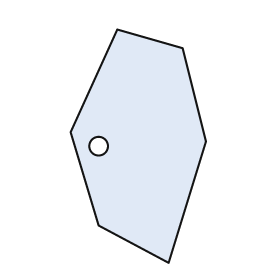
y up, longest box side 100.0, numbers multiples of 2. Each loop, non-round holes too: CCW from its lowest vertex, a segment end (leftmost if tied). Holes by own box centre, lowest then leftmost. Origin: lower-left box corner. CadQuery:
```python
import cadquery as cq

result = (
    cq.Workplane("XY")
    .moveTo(42.0, 0.0)
    .lineTo(58.0, 52.0)
    .lineTo(48.0, 92.0)
    .lineTo(20.0, 100.0)
    .lineTo(0.0, 56.0)
    .lineTo(12.0, 16.0)
    .close()
    .moveTo(12.0, 50.0)
    .circle(4.0)
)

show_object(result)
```